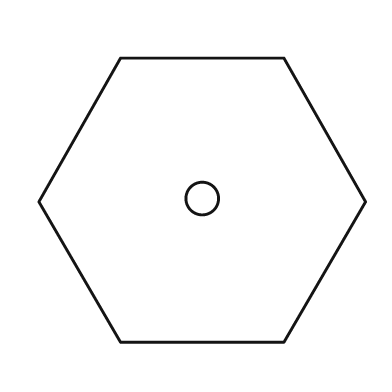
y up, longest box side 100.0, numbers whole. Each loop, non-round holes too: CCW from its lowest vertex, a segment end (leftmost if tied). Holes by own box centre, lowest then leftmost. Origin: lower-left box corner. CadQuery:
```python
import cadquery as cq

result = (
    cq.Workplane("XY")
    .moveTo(25.0, 0.0)
    .lineTo(75.0, 0.0)
    .lineTo(100.0, 43.0)
    .lineTo(75.0, 87.0)
    .lineTo(25.0, 87.0)
    .lineTo(0.0, 43.0)
    .close()
    .moveTo(50.0, 44.0)
    .circle(5.0)
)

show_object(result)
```